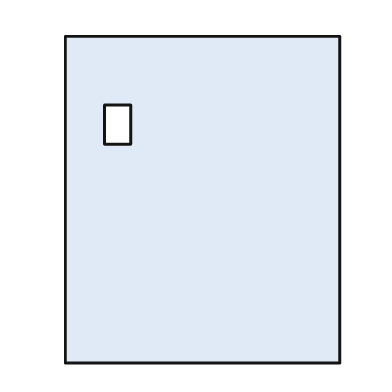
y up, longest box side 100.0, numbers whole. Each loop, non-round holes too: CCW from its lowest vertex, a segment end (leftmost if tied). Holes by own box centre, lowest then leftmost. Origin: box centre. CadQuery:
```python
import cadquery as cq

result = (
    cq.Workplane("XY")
    .moveTo(-42.0, -50.0)
    .lineTo(42.0, -50.0)
    .lineTo(42.0, 50.0)
    .lineTo(-42.0, 50.0)
    .close()
    .moveTo(-30.0, 17.0)
    .lineTo(-22.0, 17.0)
    .lineTo(-22.0, 29.0)
    .lineTo(-30.0, 29.0)
    .close()
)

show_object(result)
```